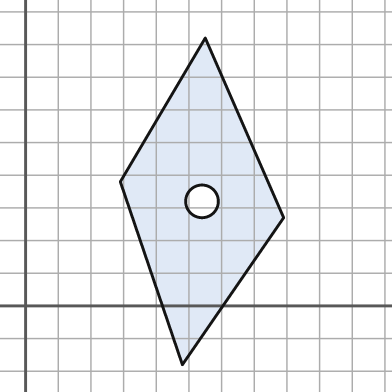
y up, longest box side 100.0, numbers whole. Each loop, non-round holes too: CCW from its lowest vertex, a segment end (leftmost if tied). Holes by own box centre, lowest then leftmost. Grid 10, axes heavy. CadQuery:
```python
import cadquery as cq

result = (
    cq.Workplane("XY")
    .moveTo(48.0, -18.0)
    .lineTo(79.0, 27.0)
    .lineTo(55.0, 82.0)
    .lineTo(29.0, 38.0)
    .close()
    .moveTo(54.0, 32.0)
    .circle(5.0)
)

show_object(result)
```